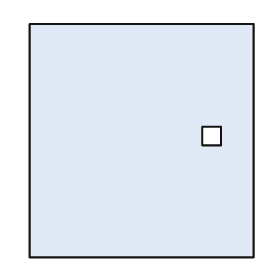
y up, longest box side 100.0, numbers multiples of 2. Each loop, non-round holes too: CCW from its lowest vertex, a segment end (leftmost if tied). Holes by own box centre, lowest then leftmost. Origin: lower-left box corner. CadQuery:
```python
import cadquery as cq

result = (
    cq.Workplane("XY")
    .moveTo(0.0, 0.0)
    .lineTo(96.0, 0.0)
    .lineTo(96.0, 100.0)
    .lineTo(0.0, 100.0)
    .close()
    .moveTo(74.0, 48.0)
    .lineTo(82.0, 48.0)
    .lineTo(82.0, 56.0)
    .lineTo(74.0, 56.0)
    .close()
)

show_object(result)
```